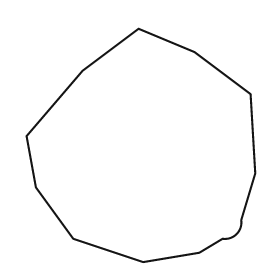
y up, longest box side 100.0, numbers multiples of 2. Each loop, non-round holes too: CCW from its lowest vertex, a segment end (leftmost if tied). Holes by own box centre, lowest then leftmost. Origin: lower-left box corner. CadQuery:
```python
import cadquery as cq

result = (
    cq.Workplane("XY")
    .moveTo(50.0, 0.0)
    .lineTo(74.0, 4.0)
    .lineTo(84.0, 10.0)
    .threePointArc((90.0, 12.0), (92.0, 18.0))
    .lineTo(98.0, 38.0)
    .lineTo(96.0, 72.0)
    .lineTo(72.0, 90.0)
    .lineTo(48.0, 100.0)
    .lineTo(24.0, 82.0)
    .lineTo(0.0, 54.0)
    .lineTo(4.0, 32.0)
    .lineTo(20.0, 10.0)
    .close()
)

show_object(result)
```